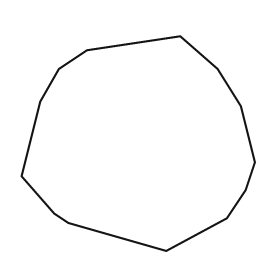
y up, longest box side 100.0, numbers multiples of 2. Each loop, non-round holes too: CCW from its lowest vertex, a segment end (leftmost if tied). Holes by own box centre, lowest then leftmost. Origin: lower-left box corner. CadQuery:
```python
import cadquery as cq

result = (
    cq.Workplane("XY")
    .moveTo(62.0, 0.0)
    .lineTo(88.0, 14.0)
    .lineTo(96.0, 26.0)
    .lineTo(100.0, 38.0)
    .lineTo(94.0, 62.0)
    .lineTo(84.0, 78.0)
    .lineTo(68.0, 92.0)
    .lineTo(28.0, 86.0)
    .lineTo(16.0, 78.0)
    .lineTo(8.0, 64.0)
    .lineTo(0.0, 32.0)
    .lineTo(14.0, 16.0)
    .lineTo(20.0, 12.0)
    .close()
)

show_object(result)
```